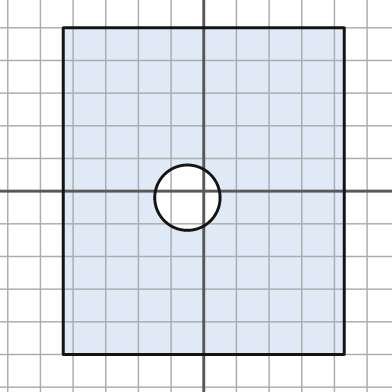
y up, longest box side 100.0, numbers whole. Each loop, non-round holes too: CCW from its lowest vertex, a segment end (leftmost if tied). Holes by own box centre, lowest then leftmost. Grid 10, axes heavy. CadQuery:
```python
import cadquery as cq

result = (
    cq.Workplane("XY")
    .moveTo(-43.0, -50.0)
    .lineTo(43.0, -50.0)
    .lineTo(43.0, 50.0)
    .lineTo(-43.0, 50.0)
    .close()
    .moveTo(-5.0, -2.0)
    .circle(10.0)
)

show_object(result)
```